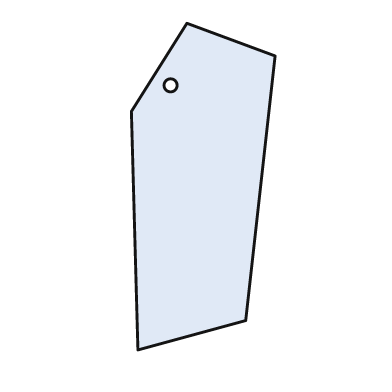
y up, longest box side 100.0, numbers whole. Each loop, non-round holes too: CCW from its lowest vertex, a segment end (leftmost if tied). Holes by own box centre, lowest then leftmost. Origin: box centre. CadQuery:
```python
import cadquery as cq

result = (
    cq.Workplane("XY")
    .moveTo(-20.0, -50.0)
    .lineTo(13.0, -41.0)
    .lineTo(22.0, 40.0)
    .lineTo(-5.0, 50.0)
    .lineTo(-22.0, 23.0)
    .close()
    .moveTo(-10.0, 31.0)
    .circle(2.0)
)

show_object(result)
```